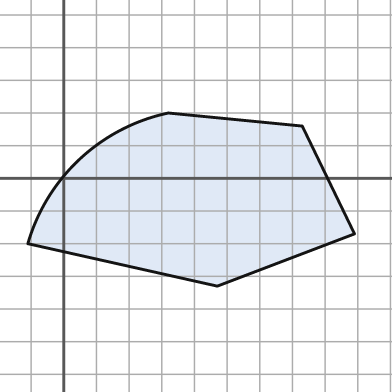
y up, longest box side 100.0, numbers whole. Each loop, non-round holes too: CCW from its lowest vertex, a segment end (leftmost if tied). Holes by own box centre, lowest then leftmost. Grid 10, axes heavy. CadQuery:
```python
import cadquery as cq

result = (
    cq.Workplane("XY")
    .moveTo(47.0, -33.0)
    .lineTo(89.0, -17.0)
    .lineTo(73.0, 16.0)
    .lineTo(32.0, 20.0)
    .threePointArc((5.0, 6.0), (-11.0, -20.0))
    .close()
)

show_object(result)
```